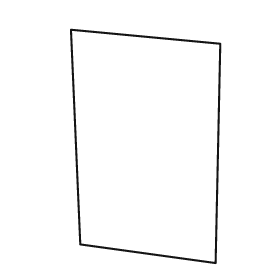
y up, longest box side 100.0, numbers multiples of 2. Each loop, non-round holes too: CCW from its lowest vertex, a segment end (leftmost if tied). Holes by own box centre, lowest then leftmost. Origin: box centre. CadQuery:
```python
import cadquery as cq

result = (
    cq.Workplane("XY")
    .moveTo(30.0, -50.0)
    .lineTo(32.0, 44.0)
    .lineTo(-32.0, 50.0)
    .lineTo(-28.0, -42.0)
    .close()
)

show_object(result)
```